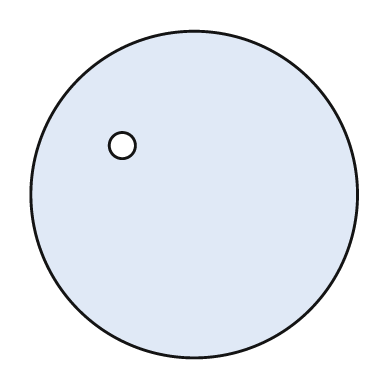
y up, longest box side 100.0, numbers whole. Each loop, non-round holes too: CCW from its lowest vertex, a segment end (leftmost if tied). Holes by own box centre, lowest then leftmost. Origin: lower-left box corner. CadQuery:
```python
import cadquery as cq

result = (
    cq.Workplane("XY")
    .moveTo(50.0, 50.0)
    .circle(50.0)
    .moveTo(28.0, 65.0)
    .circle(4.0)
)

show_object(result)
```